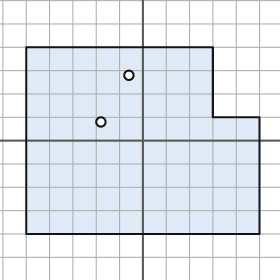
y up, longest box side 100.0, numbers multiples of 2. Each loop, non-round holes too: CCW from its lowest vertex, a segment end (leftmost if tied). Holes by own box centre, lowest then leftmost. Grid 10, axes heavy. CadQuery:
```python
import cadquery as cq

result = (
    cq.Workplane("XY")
    .moveTo(-50.0, -40.0)
    .lineTo(50.0, -40.0)
    .lineTo(50.0, 10.0)
    .lineTo(30.0, 10.0)
    .lineTo(30.0, 40.0)
    .lineTo(-50.0, 40.0)
    .close()
    .moveTo(-18.0, 8.0)
    .circle(2.0)
    .moveTo(-6.0, 28.0)
    .circle(2.0)
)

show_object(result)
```